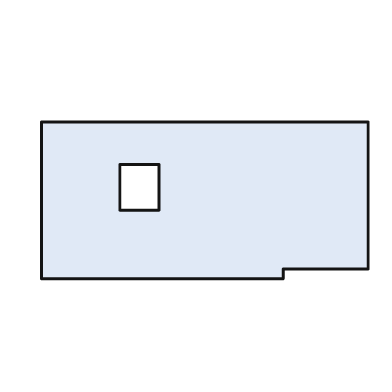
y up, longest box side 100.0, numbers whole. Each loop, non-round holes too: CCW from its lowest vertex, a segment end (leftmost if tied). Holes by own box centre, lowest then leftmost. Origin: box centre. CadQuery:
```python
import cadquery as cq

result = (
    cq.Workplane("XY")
    .moveTo(-50.0, -24.0)
    .lineTo(24.0, -24.0)
    .lineTo(24.0, -21.0)
    .lineTo(50.0, -21.0)
    .lineTo(50.0, 24.0)
    .lineTo(-50.0, 24.0)
    .close()
    .moveTo(-26.0, -3.0)
    .lineTo(-14.0, -3.0)
    .lineTo(-14.0, 11.0)
    .lineTo(-26.0, 11.0)
    .close()
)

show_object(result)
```